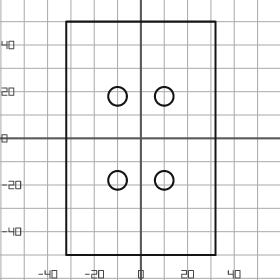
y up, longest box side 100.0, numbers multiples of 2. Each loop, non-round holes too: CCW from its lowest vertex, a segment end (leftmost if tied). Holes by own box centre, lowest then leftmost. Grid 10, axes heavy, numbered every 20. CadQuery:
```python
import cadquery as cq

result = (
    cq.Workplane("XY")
    .moveTo(-32.0, -50.0)
    .lineTo(32.0, -50.0)
    .lineTo(32.0, 50.0)
    .lineTo(-32.0, 50.0)
    .close()
    .moveTo(-10.0, -18.0)
    .circle(4.0)
    .moveTo(10.0, -18.0)
    .circle(4.0)
    .moveTo(-10.0, 18.0)
    .circle(4.0)
    .moveTo(10.0, 18.0)
    .circle(4.0)
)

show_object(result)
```